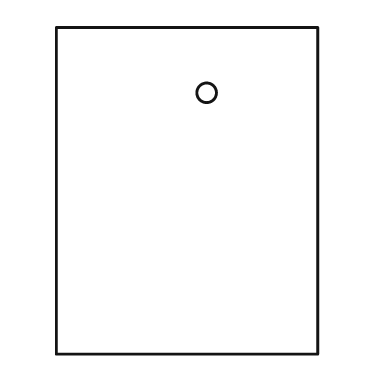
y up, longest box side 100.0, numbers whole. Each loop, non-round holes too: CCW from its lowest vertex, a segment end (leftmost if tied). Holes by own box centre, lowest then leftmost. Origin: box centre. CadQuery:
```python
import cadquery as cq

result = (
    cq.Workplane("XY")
    .moveTo(-40.0, -50.0)
    .lineTo(40.0, -50.0)
    .lineTo(40.0, 50.0)
    .lineTo(-40.0, 50.0)
    .close()
    .moveTo(6.0, 30.0)
    .circle(3.0)
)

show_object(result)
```